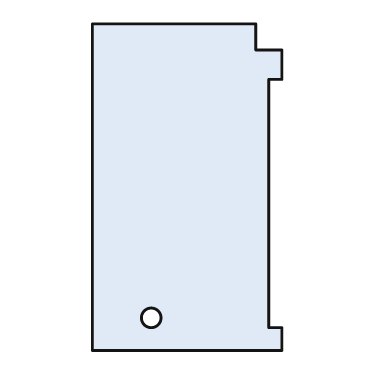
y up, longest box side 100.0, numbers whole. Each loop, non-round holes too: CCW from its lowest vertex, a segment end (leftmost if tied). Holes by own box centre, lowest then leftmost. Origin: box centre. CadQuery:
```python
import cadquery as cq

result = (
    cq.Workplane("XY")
    .moveTo(-29.0, -50.0)
    .lineTo(29.0, -50.0)
    .lineTo(29.0, -43.0)
    .lineTo(25.0, -43.0)
    .lineTo(25.0, 33.0)
    .lineTo(29.0, 33.0)
    .lineTo(29.0, 42.0)
    .lineTo(21.0, 42.0)
    .lineTo(21.0, 50.0)
    .lineTo(-29.0, 50.0)
    .close()
    .moveTo(-11.0, -40.0)
    .circle(3.0)
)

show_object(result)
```